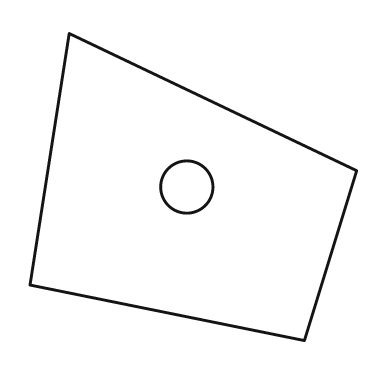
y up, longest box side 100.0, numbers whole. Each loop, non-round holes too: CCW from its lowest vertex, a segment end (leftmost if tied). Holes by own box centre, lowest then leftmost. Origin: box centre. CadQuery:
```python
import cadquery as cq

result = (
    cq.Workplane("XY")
    .moveTo(34.0, -47.0)
    .lineTo(50.0, 5.0)
    .lineTo(-38.0, 47.0)
    .lineTo(-50.0, -30.0)
    .close()
    .moveTo(-2.0, 0.0)
    .circle(8.0)
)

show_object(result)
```